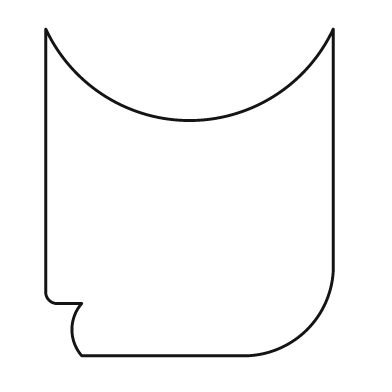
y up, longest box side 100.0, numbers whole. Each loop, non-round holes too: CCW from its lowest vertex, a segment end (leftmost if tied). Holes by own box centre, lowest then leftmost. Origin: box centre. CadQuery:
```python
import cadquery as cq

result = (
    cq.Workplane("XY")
    .moveTo(-33.0, -50.0)
    .lineTo(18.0, -50.0)
    .threePointArc((36.0, -42.0), (44.0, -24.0))
    .lineTo(44.0, 50.0)
    .threePointArc((0.0, 22.0), (-44.0, 50.0))
    .lineTo(-44.0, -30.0)
    .threePointArc((-43.0, -33.0), (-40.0, -34.0))
    .lineTo(-33.0, -34.0)
    .threePointArc((-36.0, -42.0), (-33.0, -50.0))
    .close()
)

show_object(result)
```